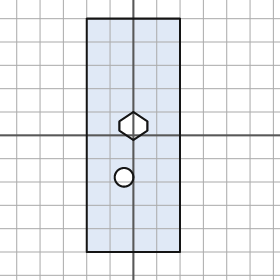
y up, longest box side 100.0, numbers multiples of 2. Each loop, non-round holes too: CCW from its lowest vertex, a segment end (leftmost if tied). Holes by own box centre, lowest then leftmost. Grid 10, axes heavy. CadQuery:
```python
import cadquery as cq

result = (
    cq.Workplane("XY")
    .moveTo(-20.0, -50.0)
    .lineTo(20.0, -50.0)
    .lineTo(20.0, 50.0)
    .lineTo(-20.0, 50.0)
    .close()
    .moveTo(-4.0, -18.0)
    .circle(4.0)
    .moveTo(0.0, -2.0)
    .lineTo(6.0, 2.0)
    .lineTo(6.0, 6.0)
    .lineTo(0.0, 10.0)
    .lineTo(-6.0, 6.0)
    .lineTo(-6.0, 2.0)
    .close()
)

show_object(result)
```